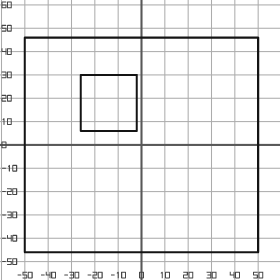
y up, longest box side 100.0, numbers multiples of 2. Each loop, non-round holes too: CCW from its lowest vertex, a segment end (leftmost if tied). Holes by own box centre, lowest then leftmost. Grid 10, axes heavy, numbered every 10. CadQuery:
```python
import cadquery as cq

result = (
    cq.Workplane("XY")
    .moveTo(-50.0, -46.0)
    .lineTo(50.0, -46.0)
    .lineTo(50.0, 46.0)
    .lineTo(-50.0, 46.0)
    .close()
    .moveTo(-26.0, 6.0)
    .lineTo(-2.0, 6.0)
    .lineTo(-2.0, 30.0)
    .lineTo(-26.0, 30.0)
    .close()
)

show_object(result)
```